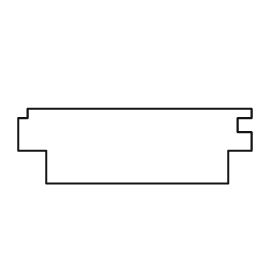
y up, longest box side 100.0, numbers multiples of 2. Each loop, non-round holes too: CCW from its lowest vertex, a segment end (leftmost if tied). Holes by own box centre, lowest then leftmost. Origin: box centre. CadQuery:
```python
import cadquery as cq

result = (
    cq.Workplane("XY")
    .moveTo(-38.0, -16.0)
    .lineTo(40.0, -16.0)
    .lineTo(40.0, -2.0)
    .lineTo(50.0, -2.0)
    .lineTo(50.0, 6.0)
    .lineTo(44.0, 6.0)
    .lineTo(44.0, 12.0)
    .lineTo(50.0, 12.0)
    .lineTo(50.0, 16.0)
    .lineTo(-46.0, 16.0)
    .lineTo(-46.0, 12.0)
    .lineTo(-50.0, 12.0)
    .lineTo(-50.0, -2.0)
    .lineTo(-38.0, -2.0)
    .close()
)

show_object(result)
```